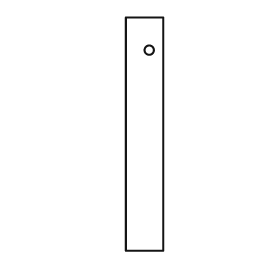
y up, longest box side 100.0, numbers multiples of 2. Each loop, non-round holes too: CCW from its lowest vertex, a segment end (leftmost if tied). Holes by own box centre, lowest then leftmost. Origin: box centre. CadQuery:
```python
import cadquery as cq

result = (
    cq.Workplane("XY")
    .moveTo(-8.0, -50.0)
    .lineTo(8.0, -50.0)
    .lineTo(8.0, 50.0)
    .lineTo(-8.0, 50.0)
    .close()
    .moveTo(2.0, 36.0)
    .circle(2.0)
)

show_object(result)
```